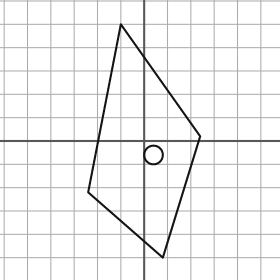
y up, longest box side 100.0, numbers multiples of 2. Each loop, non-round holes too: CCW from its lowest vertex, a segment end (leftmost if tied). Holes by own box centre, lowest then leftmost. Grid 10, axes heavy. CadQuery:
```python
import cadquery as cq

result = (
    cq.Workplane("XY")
    .moveTo(8.0, -50.0)
    .lineTo(24.0, 2.0)
    .lineTo(-10.0, 50.0)
    .lineTo(-24.0, -22.0)
    .close()
    .moveTo(4.0, -6.0)
    .circle(4.0)
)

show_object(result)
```